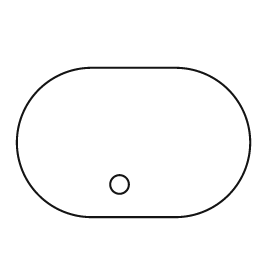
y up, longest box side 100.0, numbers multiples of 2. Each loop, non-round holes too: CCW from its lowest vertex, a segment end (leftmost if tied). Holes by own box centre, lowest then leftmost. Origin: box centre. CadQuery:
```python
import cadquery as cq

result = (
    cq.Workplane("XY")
    .moveTo(-18.0, -32.0)
    .lineTo(18.0, -32.0)
    .threePointArc((50.0, 0.0), (18.0, 32.0))
    .lineTo(-18.0, 32.0)
    .threePointArc((-50.0, 0.0), (-18.0, -32.0))
    .close()
    .moveTo(-6.0, -18.0)
    .circle(4.0)
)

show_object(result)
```